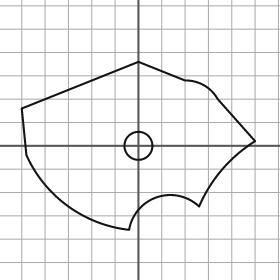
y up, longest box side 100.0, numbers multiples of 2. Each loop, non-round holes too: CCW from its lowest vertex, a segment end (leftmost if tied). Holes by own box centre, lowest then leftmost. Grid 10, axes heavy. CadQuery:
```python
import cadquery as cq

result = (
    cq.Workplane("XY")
    .moveTo(-4.0, -36.0)
    .threePointArc((8.0, -22.0), (26.0, -26.0))
    .threePointArc((36.0, -10.0), (50.0, 2.0))
    .lineTo(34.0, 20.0)
    .threePointArc((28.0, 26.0), (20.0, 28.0))
    .lineTo(0.0, 36.0)
    .lineTo(-50.0, 16.0)
    .lineTo(-48.0, -4.0)
    .threePointArc((-30.0, -26.0), (-4.0, -36.0))
    .close()
    .moveTo(0.0, 0.0)
    .circle(6.0)
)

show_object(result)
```